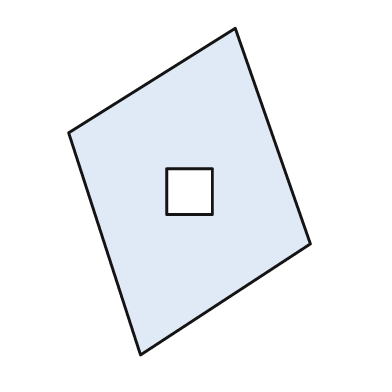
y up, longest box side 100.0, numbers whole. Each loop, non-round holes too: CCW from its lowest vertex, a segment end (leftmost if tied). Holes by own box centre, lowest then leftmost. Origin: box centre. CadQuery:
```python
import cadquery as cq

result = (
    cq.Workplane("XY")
    .moveTo(-15.0, -50.0)
    .lineTo(37.0, -16.0)
    .lineTo(14.0, 50.0)
    .lineTo(-37.0, 18.0)
    .close()
    .moveTo(-7.0, -7.0)
    .lineTo(7.0, -7.0)
    .lineTo(7.0, 7.0)
    .lineTo(-7.0, 7.0)
    .close()
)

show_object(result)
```